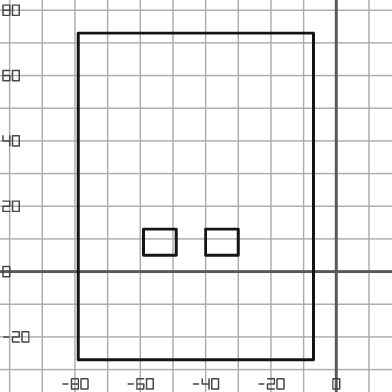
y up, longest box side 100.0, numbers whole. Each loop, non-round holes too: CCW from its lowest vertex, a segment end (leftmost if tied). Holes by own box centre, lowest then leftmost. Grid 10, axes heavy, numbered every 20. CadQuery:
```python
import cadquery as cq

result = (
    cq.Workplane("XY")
    .moveTo(-79.0, -27.0)
    .lineTo(-7.0, -27.0)
    .lineTo(-7.0, 73.0)
    .lineTo(-79.0, 73.0)
    .close()
    .moveTo(-59.0, 5.0)
    .lineTo(-49.0, 5.0)
    .lineTo(-49.0, 13.0)
    .lineTo(-59.0, 13.0)
    .close()
    .moveTo(-40.0, 5.0)
    .lineTo(-30.0, 5.0)
    .lineTo(-30.0, 13.0)
    .lineTo(-40.0, 13.0)
    .close()
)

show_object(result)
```